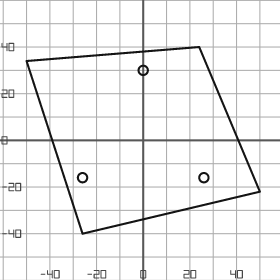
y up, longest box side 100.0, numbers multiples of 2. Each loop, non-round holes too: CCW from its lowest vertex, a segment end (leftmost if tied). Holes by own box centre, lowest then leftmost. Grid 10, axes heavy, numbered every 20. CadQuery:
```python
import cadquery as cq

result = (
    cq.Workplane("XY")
    .moveTo(-26.0, -40.0)
    .lineTo(50.0, -22.0)
    .lineTo(24.0, 40.0)
    .lineTo(-50.0, 34.0)
    .close()
    .moveTo(-26.0, -16.0)
    .circle(2.0)
    .moveTo(26.0, -16.0)
    .circle(2.0)
    .moveTo(0.0, 30.0)
    .circle(2.0)
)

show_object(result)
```